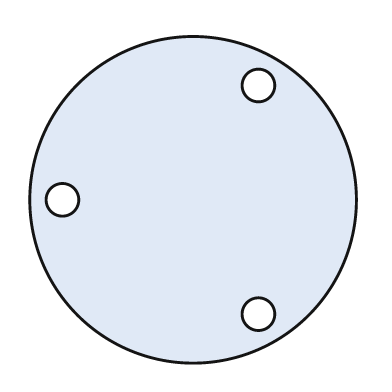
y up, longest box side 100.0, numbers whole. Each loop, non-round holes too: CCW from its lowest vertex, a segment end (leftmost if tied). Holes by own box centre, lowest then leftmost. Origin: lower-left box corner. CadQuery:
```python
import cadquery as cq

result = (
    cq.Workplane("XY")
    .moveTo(50.0, 50.0)
    .circle(50.0)
    .moveTo(70.0, 15.0)
    .circle(5.0)
    .moveTo(10.0, 50.0)
    .circle(5.0)
    .moveTo(70.0, 85.0)
    .circle(5.0)
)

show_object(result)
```